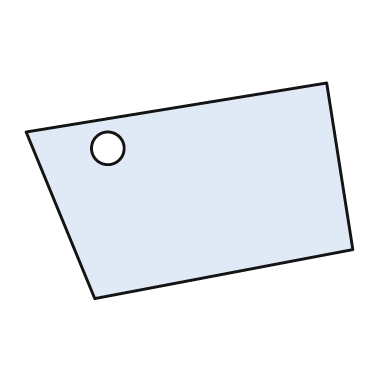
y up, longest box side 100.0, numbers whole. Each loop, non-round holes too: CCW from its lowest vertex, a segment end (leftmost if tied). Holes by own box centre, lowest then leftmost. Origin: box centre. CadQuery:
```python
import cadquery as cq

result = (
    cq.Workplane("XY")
    .moveTo(-29.0, -33.0)
    .lineTo(50.0, -18.0)
    .lineTo(42.0, 33.0)
    .lineTo(-50.0, 18.0)
    .close()
    .moveTo(-25.0, 13.0)
    .circle(5.0)
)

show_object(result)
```